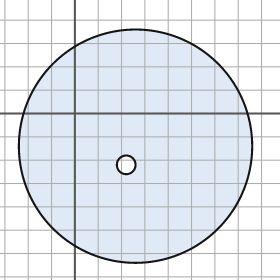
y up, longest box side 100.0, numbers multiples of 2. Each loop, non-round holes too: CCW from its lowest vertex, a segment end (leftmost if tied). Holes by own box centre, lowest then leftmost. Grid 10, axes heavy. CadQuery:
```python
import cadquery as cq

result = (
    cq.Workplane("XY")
    .moveTo(26.0, -14.0)
    .circle(50.0)
    .moveTo(22.0, -22.0)
    .circle(4.0)
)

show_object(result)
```